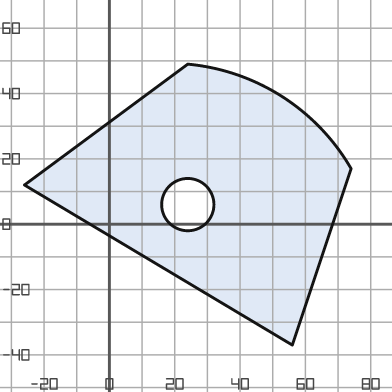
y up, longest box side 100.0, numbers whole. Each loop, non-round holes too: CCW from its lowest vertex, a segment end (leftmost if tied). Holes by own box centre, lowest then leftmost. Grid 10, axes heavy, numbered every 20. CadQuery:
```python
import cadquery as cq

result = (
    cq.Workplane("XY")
    .moveTo(56.0, -37.0)
    .lineTo(74.0, 17.0)
    .threePointArc((53.0, 39.0), (24.0, 49.0))
    .lineTo(-26.0, 12.0)
    .close()
    .moveTo(24.0, 6.0)
    .circle(8.0)
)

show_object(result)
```